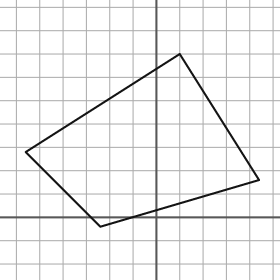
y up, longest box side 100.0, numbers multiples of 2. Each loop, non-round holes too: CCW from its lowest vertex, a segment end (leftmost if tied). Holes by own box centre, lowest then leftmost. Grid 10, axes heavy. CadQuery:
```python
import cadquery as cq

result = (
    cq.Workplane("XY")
    .moveTo(-24.0, -4.0)
    .lineTo(44.0, 16.0)
    .lineTo(10.0, 70.0)
    .lineTo(-56.0, 28.0)
    .close()
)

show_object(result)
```